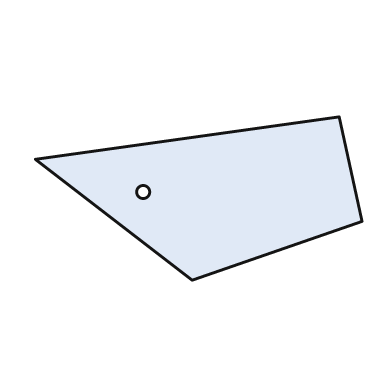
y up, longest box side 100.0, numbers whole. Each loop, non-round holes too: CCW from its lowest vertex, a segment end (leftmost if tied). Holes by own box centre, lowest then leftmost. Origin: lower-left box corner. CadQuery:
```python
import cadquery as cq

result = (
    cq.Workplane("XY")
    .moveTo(48.0, 0.0)
    .lineTo(100.0, 18.0)
    .lineTo(93.0, 50.0)
    .lineTo(0.0, 37.0)
    .close()
    .moveTo(33.0, 27.0)
    .circle(2.0)
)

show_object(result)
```